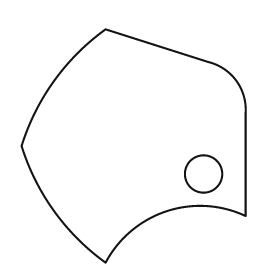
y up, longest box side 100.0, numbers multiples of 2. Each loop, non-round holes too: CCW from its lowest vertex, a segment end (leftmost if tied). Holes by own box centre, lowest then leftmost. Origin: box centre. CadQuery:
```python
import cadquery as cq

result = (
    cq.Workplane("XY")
    .moveTo(-12.0, -50.0)
    .threePointArc((14.0, -28.0), (48.0, -30.0))
    .lineTo(48.0, 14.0)
    .threePointArc((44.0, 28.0), (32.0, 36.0))
    .lineTo(-12.0, 50.0)
    .threePointArc((-34.0, 28.0), (-48.0, 0.0))
    .threePointArc((-34.0, -28.0), (-12.0, -50.0))
    .close()
    .moveTo(30.0, -12.0)
    .circle(8.0)
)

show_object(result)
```